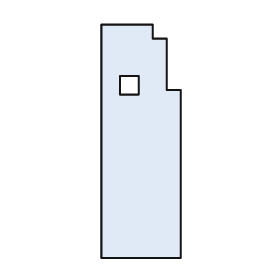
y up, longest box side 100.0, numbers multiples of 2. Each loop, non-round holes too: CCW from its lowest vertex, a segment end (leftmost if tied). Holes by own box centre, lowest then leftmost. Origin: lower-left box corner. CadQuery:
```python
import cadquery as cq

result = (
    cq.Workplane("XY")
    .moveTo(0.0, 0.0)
    .lineTo(34.0, 0.0)
    .lineTo(34.0, 72.0)
    .lineTo(28.0, 72.0)
    .lineTo(28.0, 94.0)
    .lineTo(22.0, 94.0)
    .lineTo(22.0, 100.0)
    .lineTo(0.0, 100.0)
    .close()
    .moveTo(8.0, 70.0)
    .lineTo(16.0, 70.0)
    .lineTo(16.0, 78.0)
    .lineTo(8.0, 78.0)
    .close()
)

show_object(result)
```